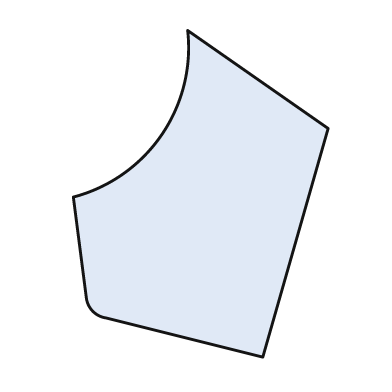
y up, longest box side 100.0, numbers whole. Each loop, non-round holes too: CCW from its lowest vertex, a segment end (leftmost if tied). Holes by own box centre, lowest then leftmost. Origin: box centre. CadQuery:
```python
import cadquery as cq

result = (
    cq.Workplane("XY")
    .moveTo(19.0, -50.0)
    .lineTo(39.0, 20.0)
    .lineTo(-4.0, 50.0)
    .threePointArc((-12.0, 18.0), (-39.0, -1.0))
    .lineTo(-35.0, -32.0)
    .threePointArc((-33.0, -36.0), (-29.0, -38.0))
    .close()
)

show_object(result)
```